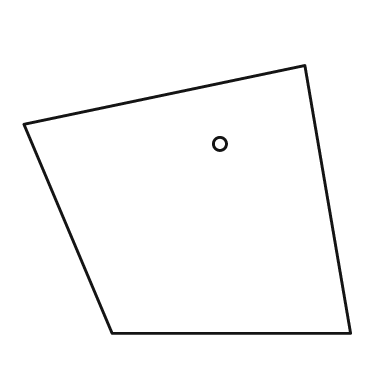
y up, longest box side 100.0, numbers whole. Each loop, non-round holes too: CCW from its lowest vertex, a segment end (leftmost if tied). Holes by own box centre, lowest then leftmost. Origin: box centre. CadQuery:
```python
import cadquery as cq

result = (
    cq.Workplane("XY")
    .moveTo(-23.0, -41.0)
    .lineTo(50.0, -41.0)
    .lineTo(36.0, 41.0)
    .lineTo(-50.0, 23.0)
    .close()
    .moveTo(10.0, 17.0)
    .circle(2.0)
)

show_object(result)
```